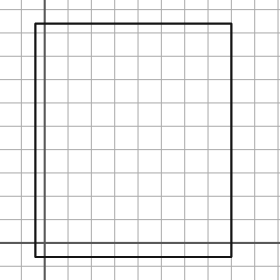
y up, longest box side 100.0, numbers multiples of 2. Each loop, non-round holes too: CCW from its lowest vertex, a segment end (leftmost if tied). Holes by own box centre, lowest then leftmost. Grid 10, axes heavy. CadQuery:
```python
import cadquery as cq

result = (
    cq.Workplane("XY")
    .moveTo(-4.0, -6.0)
    .lineTo(80.0, -6.0)
    .lineTo(80.0, 94.0)
    .lineTo(-4.0, 94.0)
    .close()
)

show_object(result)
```